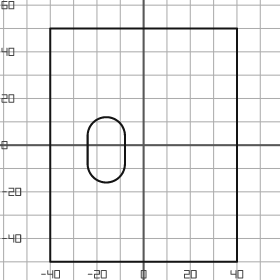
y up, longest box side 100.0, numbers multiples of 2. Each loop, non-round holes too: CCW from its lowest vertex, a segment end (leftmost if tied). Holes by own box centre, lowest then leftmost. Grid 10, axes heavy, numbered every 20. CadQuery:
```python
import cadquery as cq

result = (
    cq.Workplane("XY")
    .moveTo(-40.0, -50.0)
    .lineTo(40.0, -50.0)
    .lineTo(40.0, 50.0)
    .lineTo(-40.0, 50.0)
    .close()
    .moveTo(-24.0, -8.0)
    .threePointArc((-16.0, -16.0), (-8.0, -8.0))
    .lineTo(-8.0, 4.0)
    .threePointArc((-16.0, 12.0), (-24.0, 4.0))
    .close()
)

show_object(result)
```